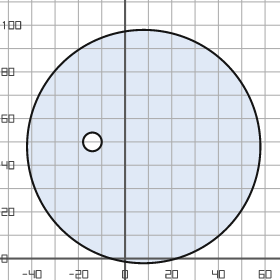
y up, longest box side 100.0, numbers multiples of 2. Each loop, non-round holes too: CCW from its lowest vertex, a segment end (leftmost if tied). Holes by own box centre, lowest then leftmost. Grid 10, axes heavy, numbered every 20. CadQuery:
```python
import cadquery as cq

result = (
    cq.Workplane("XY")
    .moveTo(8.0, 48.0)
    .circle(50.0)
    .moveTo(-14.0, 50.0)
    .circle(4.0)
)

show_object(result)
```